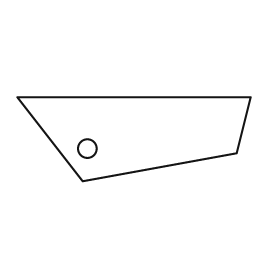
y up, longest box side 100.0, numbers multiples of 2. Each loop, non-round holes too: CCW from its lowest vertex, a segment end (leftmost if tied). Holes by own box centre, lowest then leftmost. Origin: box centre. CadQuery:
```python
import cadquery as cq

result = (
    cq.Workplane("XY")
    .moveTo(-22.0, -18.0)
    .lineTo(44.0, -6.0)
    .lineTo(50.0, 18.0)
    .lineTo(-50.0, 18.0)
    .close()
    .moveTo(-20.0, -4.0)
    .circle(4.0)
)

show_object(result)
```